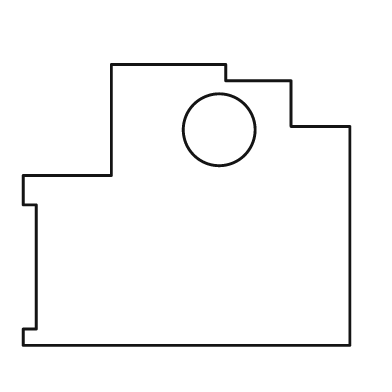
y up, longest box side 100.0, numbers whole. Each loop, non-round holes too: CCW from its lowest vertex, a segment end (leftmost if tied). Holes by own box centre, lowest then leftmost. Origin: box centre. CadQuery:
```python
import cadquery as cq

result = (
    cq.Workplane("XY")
    .moveTo(-50.0, -43.0)
    .lineTo(50.0, -43.0)
    .lineTo(50.0, 24.0)
    .lineTo(32.0, 24.0)
    .lineTo(32.0, 38.0)
    .lineTo(12.0, 38.0)
    .lineTo(12.0, 43.0)
    .lineTo(-23.0, 43.0)
    .lineTo(-23.0, 9.0)
    .lineTo(-50.0, 9.0)
    .lineTo(-50.0, 0.0)
    .lineTo(-46.0, 0.0)
    .lineTo(-46.0, -38.0)
    .lineTo(-50.0, -38.0)
    .close()
    .moveTo(10.0, 23.0)
    .circle(11.0)
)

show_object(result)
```